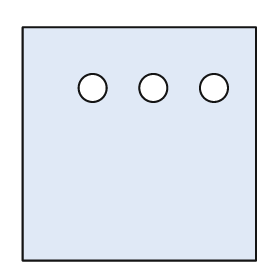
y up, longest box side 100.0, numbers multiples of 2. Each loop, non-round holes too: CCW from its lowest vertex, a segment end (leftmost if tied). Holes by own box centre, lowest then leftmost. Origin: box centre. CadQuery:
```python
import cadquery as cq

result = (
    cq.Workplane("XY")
    .moveTo(-50.0, -50.0)
    .lineTo(50.0, -50.0)
    .lineTo(50.0, 50.0)
    .lineTo(-50.0, 50.0)
    .close()
    .moveTo(-20.0, 24.0)
    .circle(6.0)
    .moveTo(6.0, 24.0)
    .circle(6.0)
    .moveTo(32.0, 24.0)
    .circle(6.0)
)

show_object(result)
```